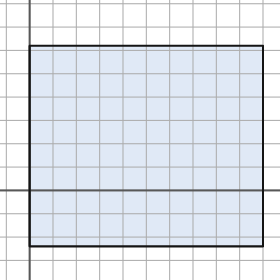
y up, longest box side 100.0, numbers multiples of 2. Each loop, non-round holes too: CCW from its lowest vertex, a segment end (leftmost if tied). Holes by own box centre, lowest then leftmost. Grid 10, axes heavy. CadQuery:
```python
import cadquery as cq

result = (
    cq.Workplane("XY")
    .moveTo(0.0, -24.0)
    .lineTo(100.0, -24.0)
    .lineTo(100.0, 62.0)
    .lineTo(0.0, 62.0)
    .close()
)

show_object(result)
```